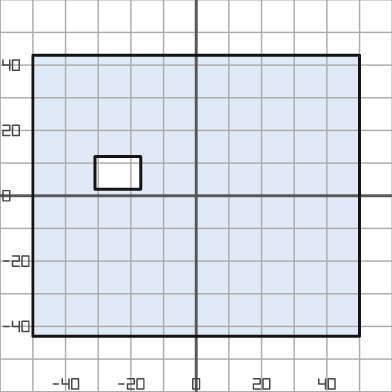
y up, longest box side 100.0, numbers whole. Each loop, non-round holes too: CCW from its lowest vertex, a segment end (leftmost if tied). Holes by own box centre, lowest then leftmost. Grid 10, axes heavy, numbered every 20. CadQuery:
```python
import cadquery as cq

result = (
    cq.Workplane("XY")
    .moveTo(-50.0, -43.0)
    .lineTo(50.0, -43.0)
    .lineTo(50.0, 43.0)
    .lineTo(-50.0, 43.0)
    .close()
    .moveTo(-31.0, 2.0)
    .lineTo(-17.0, 2.0)
    .lineTo(-17.0, 12.0)
    .lineTo(-31.0, 12.0)
    .close()
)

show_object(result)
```